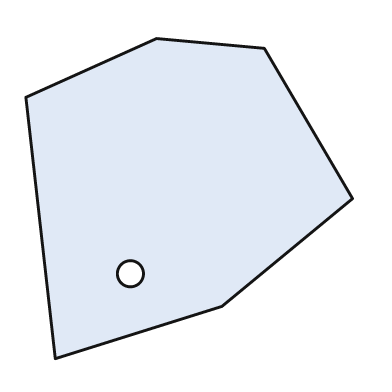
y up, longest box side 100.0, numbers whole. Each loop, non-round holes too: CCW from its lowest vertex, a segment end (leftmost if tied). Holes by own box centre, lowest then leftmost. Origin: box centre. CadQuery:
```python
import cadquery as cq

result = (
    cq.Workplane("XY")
    .moveTo(-41.0, -49.0)
    .lineTo(10.0, -33.0)
    .lineTo(50.0, 0.0)
    .lineTo(23.0, 46.0)
    .lineTo(-10.0, 49.0)
    .lineTo(-50.0, 31.0)
    .close()
    .moveTo(-18.0, -23.0)
    .circle(4.0)
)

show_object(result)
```